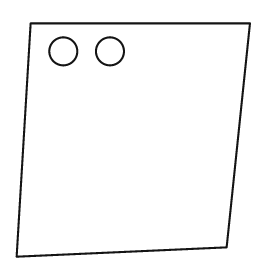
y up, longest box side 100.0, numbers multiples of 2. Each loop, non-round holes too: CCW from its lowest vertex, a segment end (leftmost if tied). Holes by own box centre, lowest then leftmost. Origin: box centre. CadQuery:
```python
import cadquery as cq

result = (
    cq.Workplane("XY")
    .moveTo(-50.0, -50.0)
    .lineTo(40.0, -46.0)
    .lineTo(50.0, 50.0)
    .lineTo(-44.0, 50.0)
    .close()
    .moveTo(-30.0, 38.0)
    .circle(6.0)
    .moveTo(-10.0, 38.0)
    .circle(6.0)
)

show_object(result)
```